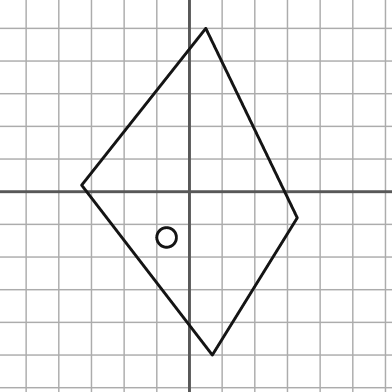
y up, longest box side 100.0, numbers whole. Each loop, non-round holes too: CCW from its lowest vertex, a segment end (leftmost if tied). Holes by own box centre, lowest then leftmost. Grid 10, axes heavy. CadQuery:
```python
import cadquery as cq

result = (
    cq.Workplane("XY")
    .moveTo(7.0, -50.0)
    .lineTo(33.0, -8.0)
    .lineTo(5.0, 50.0)
    .lineTo(-33.0, 2.0)
    .close()
    .moveTo(-7.0, -14.0)
    .circle(3.0)
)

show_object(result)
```